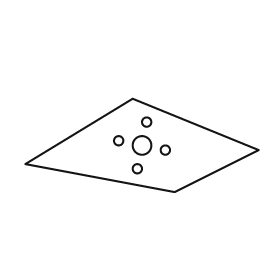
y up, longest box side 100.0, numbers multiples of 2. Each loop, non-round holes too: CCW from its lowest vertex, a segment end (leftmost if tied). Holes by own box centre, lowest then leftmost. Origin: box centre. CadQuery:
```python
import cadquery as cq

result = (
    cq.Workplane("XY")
    .moveTo(14.0, -20.0)
    .lineTo(50.0, -2.0)
    .lineTo(-4.0, 20.0)
    .lineTo(-50.0, -8.0)
    .close()
    .moveTo(-2.0, -10.0)
    .circle(2.0)
    .moveTo(10.0, -2.0)
    .circle(2.0)
    .moveTo(0.0, 0.0)
    .circle(4.0)
    .moveTo(-10.0, 2.0)
    .circle(2.0)
    .moveTo(2.0, 10.0)
    .circle(2.0)
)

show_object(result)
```